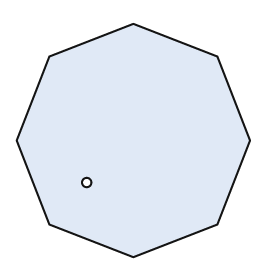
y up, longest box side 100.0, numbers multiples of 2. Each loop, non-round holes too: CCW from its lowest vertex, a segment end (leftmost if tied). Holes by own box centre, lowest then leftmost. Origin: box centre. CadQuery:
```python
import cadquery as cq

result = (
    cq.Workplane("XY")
    .moveTo(0.0, -50.0)
    .lineTo(36.0, -36.0)
    .lineTo(50.0, 0.0)
    .lineTo(36.0, 36.0)
    .lineTo(0.0, 50.0)
    .lineTo(-36.0, 36.0)
    .lineTo(-50.0, 0.0)
    .lineTo(-36.0, -36.0)
    .close()
    .moveTo(-20.0, -18.0)
    .circle(2.0)
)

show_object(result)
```